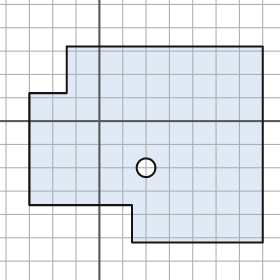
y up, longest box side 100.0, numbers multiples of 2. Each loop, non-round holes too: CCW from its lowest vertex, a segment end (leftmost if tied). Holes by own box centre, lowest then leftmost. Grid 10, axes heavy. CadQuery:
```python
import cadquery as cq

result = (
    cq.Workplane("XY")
    .moveTo(14.0, -52.0)
    .lineTo(70.0, -52.0)
    .lineTo(70.0, 32.0)
    .lineTo(-14.0, 32.0)
    .lineTo(-14.0, 12.0)
    .lineTo(-30.0, 12.0)
    .lineTo(-30.0, -36.0)
    .lineTo(14.0, -36.0)
    .close()
    .moveTo(20.0, -20.0)
    .circle(4.0)
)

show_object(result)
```